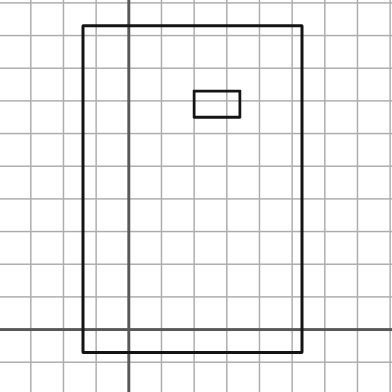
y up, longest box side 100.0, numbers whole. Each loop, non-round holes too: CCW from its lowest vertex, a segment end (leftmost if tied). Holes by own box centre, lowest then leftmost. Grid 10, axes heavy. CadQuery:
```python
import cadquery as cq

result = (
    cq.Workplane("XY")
    .moveTo(-14.0, -7.0)
    .lineTo(53.0, -7.0)
    .lineTo(53.0, 93.0)
    .lineTo(-14.0, 93.0)
    .close()
    .moveTo(20.0, 65.0)
    .lineTo(34.0, 65.0)
    .lineTo(34.0, 73.0)
    .lineTo(20.0, 73.0)
    .close()
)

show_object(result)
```